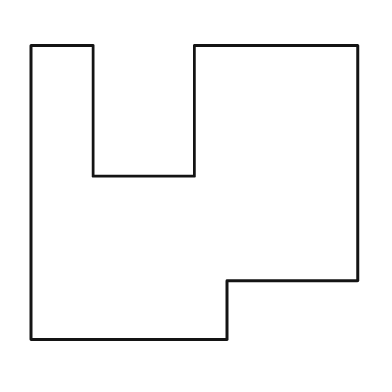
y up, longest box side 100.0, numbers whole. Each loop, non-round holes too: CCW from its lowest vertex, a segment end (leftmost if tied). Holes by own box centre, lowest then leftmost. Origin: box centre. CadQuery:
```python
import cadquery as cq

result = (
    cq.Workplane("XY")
    .moveTo(-50.0, -45.0)
    .lineTo(10.0, -45.0)
    .lineTo(10.0, -27.0)
    .lineTo(50.0, -27.0)
    .lineTo(50.0, 45.0)
    .lineTo(0.0, 45.0)
    .lineTo(0.0, 5.0)
    .lineTo(-31.0, 5.0)
    .lineTo(-31.0, 45.0)
    .lineTo(-50.0, 45.0)
    .close()
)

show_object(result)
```